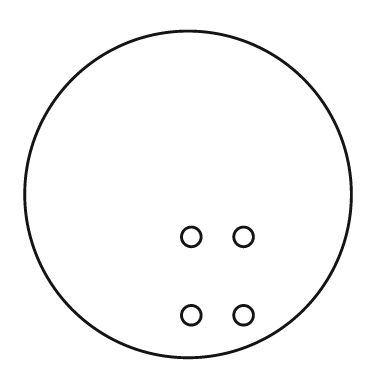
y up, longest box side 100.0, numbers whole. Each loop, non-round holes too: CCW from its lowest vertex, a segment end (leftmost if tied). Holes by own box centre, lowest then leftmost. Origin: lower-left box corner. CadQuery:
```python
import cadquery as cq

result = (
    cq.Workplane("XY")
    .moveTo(50.0, 50.0)
    .circle(50.0)
    .moveTo(51.0, 13.0)
    .circle(3.0)
    .moveTo(67.0, 13.0)
    .circle(3.0)
    .moveTo(51.0, 37.0)
    .circle(3.0)
    .moveTo(67.0, 37.0)
    .circle(3.0)
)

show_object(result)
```